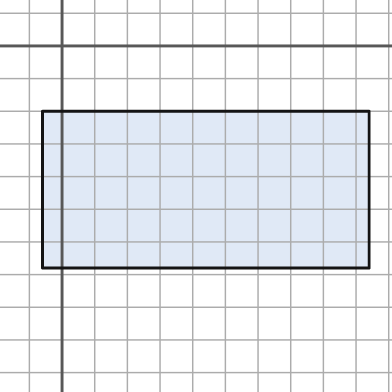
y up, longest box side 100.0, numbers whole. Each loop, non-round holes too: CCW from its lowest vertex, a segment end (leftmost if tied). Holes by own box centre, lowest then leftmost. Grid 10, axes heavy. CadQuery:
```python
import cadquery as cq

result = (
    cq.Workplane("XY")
    .moveTo(-6.0, -68.0)
    .lineTo(94.0, -68.0)
    .lineTo(94.0, -20.0)
    .lineTo(-6.0, -20.0)
    .close()
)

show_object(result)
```